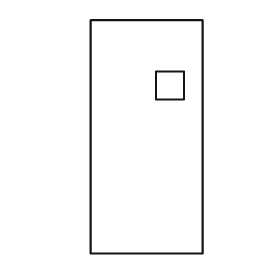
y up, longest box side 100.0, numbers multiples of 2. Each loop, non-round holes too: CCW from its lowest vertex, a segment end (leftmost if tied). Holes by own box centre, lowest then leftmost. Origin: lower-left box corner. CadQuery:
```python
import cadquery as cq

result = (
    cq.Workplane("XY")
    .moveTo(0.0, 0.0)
    .lineTo(48.0, 0.0)
    .lineTo(48.0, 100.0)
    .lineTo(0.0, 100.0)
    .close()
    .moveTo(28.0, 66.0)
    .lineTo(40.0, 66.0)
    .lineTo(40.0, 78.0)
    .lineTo(28.0, 78.0)
    .close()
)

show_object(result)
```